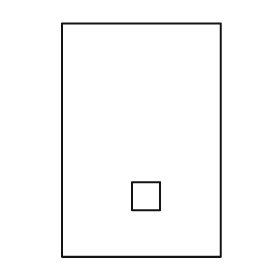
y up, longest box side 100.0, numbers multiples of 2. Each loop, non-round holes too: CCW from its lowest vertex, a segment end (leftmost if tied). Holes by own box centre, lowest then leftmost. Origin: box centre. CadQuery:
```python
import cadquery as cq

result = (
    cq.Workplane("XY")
    .moveTo(-34.0, -50.0)
    .lineTo(34.0, -50.0)
    .lineTo(34.0, 50.0)
    .lineTo(-34.0, 50.0)
    .close()
    .moveTo(-4.0, -30.0)
    .lineTo(8.0, -30.0)
    .lineTo(8.0, -18.0)
    .lineTo(-4.0, -18.0)
    .close()
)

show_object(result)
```